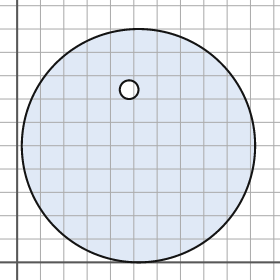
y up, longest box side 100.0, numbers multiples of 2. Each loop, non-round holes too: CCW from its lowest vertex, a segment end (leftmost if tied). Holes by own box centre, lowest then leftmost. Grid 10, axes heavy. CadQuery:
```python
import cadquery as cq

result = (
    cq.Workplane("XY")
    .moveTo(52.0, 50.0)
    .circle(50.0)
    .moveTo(48.0, 74.0)
    .circle(4.0)
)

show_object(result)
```